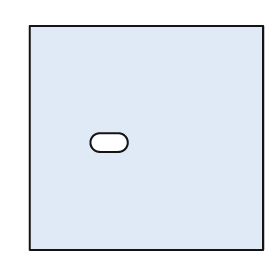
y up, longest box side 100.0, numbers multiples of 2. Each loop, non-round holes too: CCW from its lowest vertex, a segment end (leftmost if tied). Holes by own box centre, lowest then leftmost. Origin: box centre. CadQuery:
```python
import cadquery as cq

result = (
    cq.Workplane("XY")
    .moveTo(-50.0, -48.0)
    .lineTo(50.0, -48.0)
    .lineTo(50.0, 48.0)
    .lineTo(-50.0, 48.0)
    .close()
    .moveTo(-20.0, -6.0)
    .lineTo(-12.0, -6.0)
    .threePointArc((-8.0, -2.0), (-12.0, 2.0))
    .lineTo(-20.0, 2.0)
    .threePointArc((-24.0, -2.0), (-20.0, -6.0))
    .close()
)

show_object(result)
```